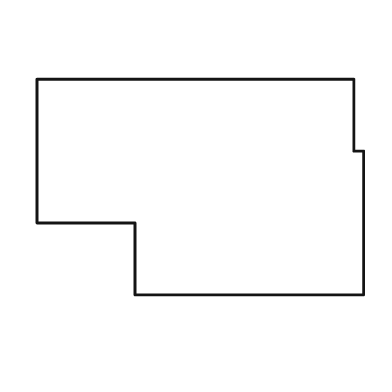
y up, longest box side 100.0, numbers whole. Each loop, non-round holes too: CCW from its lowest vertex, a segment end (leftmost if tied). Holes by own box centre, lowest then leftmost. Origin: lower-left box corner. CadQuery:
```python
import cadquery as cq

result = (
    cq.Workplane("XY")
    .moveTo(30.0, 0.0)
    .lineTo(100.0, 0.0)
    .lineTo(100.0, 44.0)
    .lineTo(97.0, 44.0)
    .lineTo(97.0, 66.0)
    .lineTo(0.0, 66.0)
    .lineTo(0.0, 22.0)
    .lineTo(30.0, 22.0)
    .close()
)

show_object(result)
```